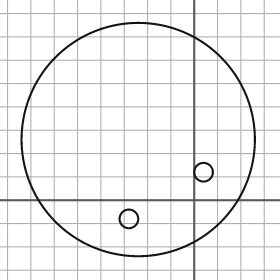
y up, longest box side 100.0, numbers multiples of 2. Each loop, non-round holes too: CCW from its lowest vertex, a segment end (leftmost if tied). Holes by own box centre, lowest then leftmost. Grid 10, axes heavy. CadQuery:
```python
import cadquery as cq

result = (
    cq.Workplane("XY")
    .moveTo(-24.0, 26.0)
    .circle(50.0)
    .moveTo(-28.0, -8.0)
    .circle(4.0)
    .moveTo(4.0, 12.0)
    .circle(4.0)
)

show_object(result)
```